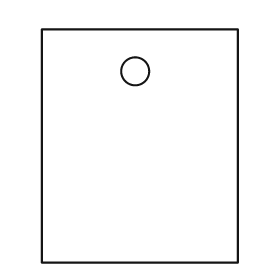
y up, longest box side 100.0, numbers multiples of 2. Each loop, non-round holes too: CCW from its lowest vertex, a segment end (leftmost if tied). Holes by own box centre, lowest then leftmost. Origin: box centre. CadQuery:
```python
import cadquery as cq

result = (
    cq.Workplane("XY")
    .moveTo(-42.0, -50.0)
    .lineTo(42.0, -50.0)
    .lineTo(42.0, 50.0)
    .lineTo(-42.0, 50.0)
    .close()
    .moveTo(-2.0, 32.0)
    .circle(6.0)
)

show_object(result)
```